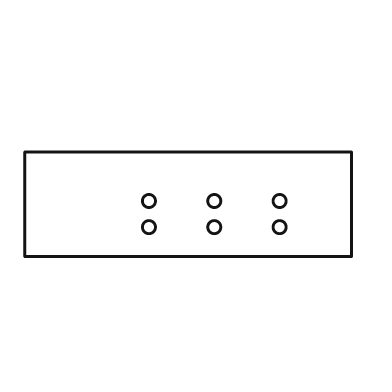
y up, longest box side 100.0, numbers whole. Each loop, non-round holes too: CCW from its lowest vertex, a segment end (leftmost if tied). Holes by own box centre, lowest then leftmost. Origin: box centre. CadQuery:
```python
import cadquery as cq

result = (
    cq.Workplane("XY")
    .moveTo(-50.0, -16.0)
    .lineTo(50.0, -16.0)
    .lineTo(50.0, 16.0)
    .lineTo(-50.0, 16.0)
    .close()
    .moveTo(-12.0, -7.0)
    .circle(2.0)
    .moveTo(8.0, -7.0)
    .circle(2.0)
    .moveTo(28.0, -7.0)
    .circle(2.0)
    .moveTo(-12.0, 1.0)
    .circle(2.0)
    .moveTo(8.0, 1.0)
    .circle(2.0)
    .moveTo(28.0, 1.0)
    .circle(2.0)
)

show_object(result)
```